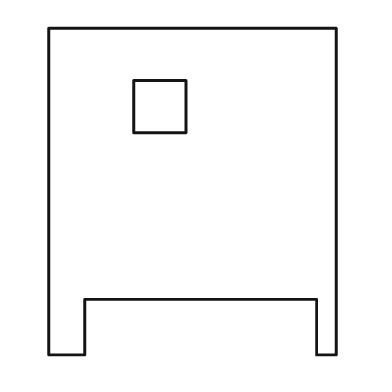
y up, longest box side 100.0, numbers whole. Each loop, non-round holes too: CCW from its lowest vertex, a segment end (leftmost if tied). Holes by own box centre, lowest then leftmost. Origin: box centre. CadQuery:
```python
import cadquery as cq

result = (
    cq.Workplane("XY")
    .moveTo(-44.0, -50.0)
    .lineTo(-33.0, -50.0)
    .lineTo(-33.0, -33.0)
    .lineTo(38.0, -33.0)
    .lineTo(38.0, -50.0)
    .lineTo(44.0, -50.0)
    .lineTo(44.0, 50.0)
    .lineTo(-44.0, 50.0)
    .close()
    .moveTo(-18.0, 18.0)
    .lineTo(-2.0, 18.0)
    .lineTo(-2.0, 34.0)
    .lineTo(-18.0, 34.0)
    .close()
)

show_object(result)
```